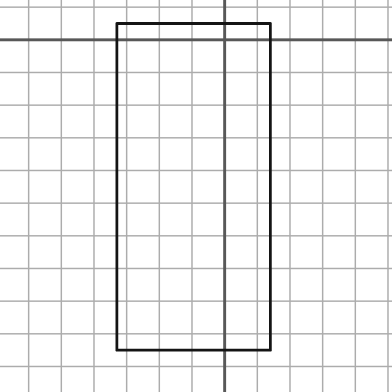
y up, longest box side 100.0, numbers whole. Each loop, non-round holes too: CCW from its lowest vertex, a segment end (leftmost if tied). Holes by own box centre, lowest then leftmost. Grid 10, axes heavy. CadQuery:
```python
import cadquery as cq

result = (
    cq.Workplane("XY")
    .moveTo(-33.0, -95.0)
    .lineTo(14.0, -95.0)
    .lineTo(14.0, 5.0)
    .lineTo(-33.0, 5.0)
    .close()
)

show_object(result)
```